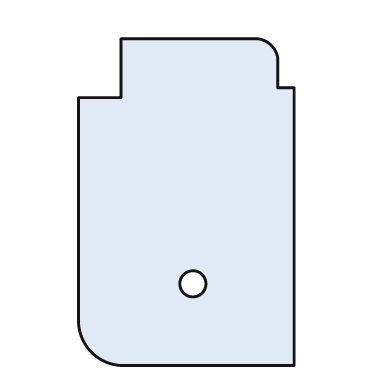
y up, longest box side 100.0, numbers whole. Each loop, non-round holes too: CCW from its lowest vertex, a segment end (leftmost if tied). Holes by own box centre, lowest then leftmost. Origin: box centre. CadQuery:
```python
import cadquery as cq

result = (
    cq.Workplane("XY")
    .moveTo(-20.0, -50.0)
    .lineTo(33.0, -50.0)
    .lineTo(33.0, 35.0)
    .lineTo(28.0, 35.0)
    .lineTo(28.0, 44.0)
    .threePointArc((26.0, 48.0), (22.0, 50.0))
    .lineTo(-20.0, 50.0)
    .lineTo(-20.0, 32.0)
    .lineTo(-33.0, 32.0)
    .lineTo(-33.0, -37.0)
    .threePointArc((-29.0, -46.0), (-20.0, -50.0))
    .close()
    .moveTo(2.0, -25.0)
    .circle(4.0)
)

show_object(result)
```